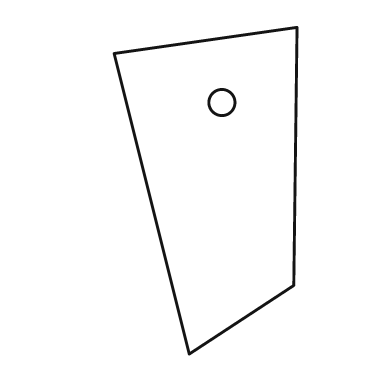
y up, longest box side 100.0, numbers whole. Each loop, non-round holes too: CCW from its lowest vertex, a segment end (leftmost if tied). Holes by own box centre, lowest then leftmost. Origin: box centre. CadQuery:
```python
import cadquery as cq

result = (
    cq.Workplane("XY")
    .moveTo(-5.0, -50.0)
    .lineTo(27.0, -29.0)
    .lineTo(28.0, 50.0)
    .lineTo(-28.0, 42.0)
    .close()
    .moveTo(5.0, 27.0)
    .circle(4.0)
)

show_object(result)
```